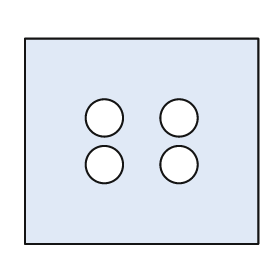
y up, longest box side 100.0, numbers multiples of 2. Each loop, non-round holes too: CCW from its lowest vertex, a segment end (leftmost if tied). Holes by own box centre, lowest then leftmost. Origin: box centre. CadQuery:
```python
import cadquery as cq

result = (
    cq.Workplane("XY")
    .moveTo(-50.0, -44.0)
    .lineTo(50.0, -44.0)
    .lineTo(50.0, 44.0)
    .lineTo(-50.0, 44.0)
    .close()
    .moveTo(-16.0, -10.0)
    .circle(8.0)
    .moveTo(16.0, -10.0)
    .circle(8.0)
    .moveTo(-16.0, 10.0)
    .circle(8.0)
    .moveTo(16.0, 10.0)
    .circle(8.0)
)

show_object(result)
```